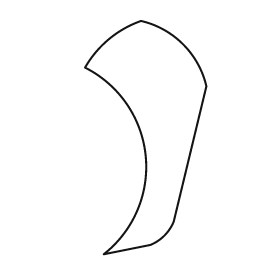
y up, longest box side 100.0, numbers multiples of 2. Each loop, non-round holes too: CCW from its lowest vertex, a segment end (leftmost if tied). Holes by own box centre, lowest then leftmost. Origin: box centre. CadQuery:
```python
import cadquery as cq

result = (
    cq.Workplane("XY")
    .moveTo(-18.0, -50.0)
    .lineTo(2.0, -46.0)
    .threePointArc((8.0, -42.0), (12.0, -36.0))
    .lineTo(26.0, 22.0)
    .threePointArc((16.0, 40.0), (-2.0, 50.0))
    .threePointArc((-16.0, 42.0), (-26.0, 30.0))
    .threePointArc((0.0, -8.0), (-18.0, -50.0))
    .close()
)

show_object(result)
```